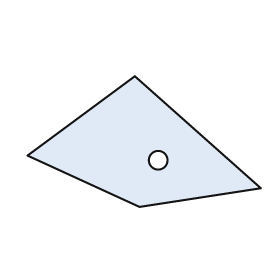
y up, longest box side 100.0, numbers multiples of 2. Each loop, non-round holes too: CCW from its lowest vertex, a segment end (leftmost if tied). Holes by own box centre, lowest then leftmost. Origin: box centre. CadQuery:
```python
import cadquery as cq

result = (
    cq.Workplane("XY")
    .moveTo(-2.0, -28.0)
    .lineTo(50.0, -20.0)
    .lineTo(-4.0, 28.0)
    .lineTo(-50.0, -6.0)
    .close()
    .moveTo(6.0, -8.0)
    .circle(4.0)
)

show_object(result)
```